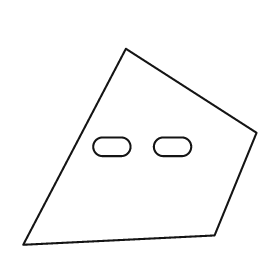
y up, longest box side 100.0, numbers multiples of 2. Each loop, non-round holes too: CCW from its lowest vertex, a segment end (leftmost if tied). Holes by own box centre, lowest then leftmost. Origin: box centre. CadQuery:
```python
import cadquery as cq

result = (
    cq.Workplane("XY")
    .moveTo(-50.0, -42.0)
    .lineTo(32.0, -38.0)
    .lineTo(50.0, 6.0)
    .lineTo(-6.0, 42.0)
    .close()
    .moveTo(-16.0, -4.0)
    .lineTo(-8.0, -4.0)
    .threePointArc((-4.0, 0.0), (-8.0, 4.0))
    .lineTo(-16.0, 4.0)
    .threePointArc((-20.0, 0.0), (-16.0, -4.0))
    .close()
    .moveTo(10.0, -4.0)
    .lineTo(18.0, -4.0)
    .threePointArc((22.0, 0.0), (18.0, 4.0))
    .lineTo(10.0, 4.0)
    .threePointArc((6.0, 0.0), (10.0, -4.0))
    .close()
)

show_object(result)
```